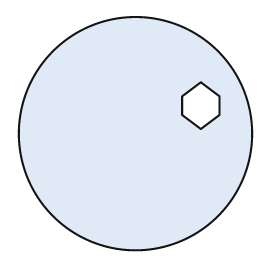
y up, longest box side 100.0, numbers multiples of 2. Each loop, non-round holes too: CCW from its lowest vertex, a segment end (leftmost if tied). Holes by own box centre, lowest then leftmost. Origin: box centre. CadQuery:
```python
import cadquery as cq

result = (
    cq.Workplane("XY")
    .moveTo(0.0, 0.0)
    .circle(50.0)
    .moveTo(28.0, 2.0)
    .lineTo(36.0, 8.0)
    .lineTo(36.0, 16.0)
    .lineTo(28.0, 22.0)
    .lineTo(20.0, 16.0)
    .lineTo(20.0, 8.0)
    .close()
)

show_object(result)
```